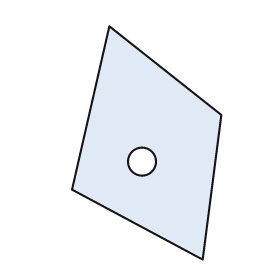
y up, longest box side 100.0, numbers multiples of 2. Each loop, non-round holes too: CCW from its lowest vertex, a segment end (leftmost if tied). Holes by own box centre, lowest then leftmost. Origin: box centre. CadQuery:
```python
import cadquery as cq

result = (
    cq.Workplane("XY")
    .moveTo(24.0, -50.0)
    .lineTo(32.0, 12.0)
    .lineTo(-16.0, 50.0)
    .lineTo(-32.0, -20.0)
    .close()
    .moveTo(-2.0, -8.0)
    .circle(6.0)
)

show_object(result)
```